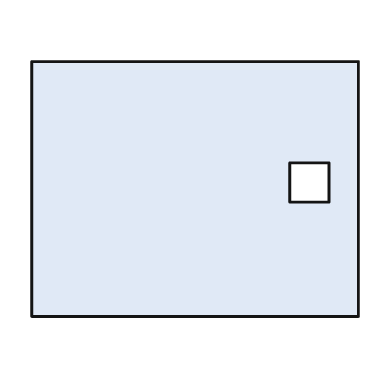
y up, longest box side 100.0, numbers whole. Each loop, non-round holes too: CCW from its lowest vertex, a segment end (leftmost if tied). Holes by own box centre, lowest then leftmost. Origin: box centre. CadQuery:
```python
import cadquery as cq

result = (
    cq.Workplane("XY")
    .moveTo(-50.0, -39.0)
    .lineTo(50.0, -39.0)
    .lineTo(50.0, 39.0)
    .lineTo(-50.0, 39.0)
    .close()
    .moveTo(29.0, -4.0)
    .lineTo(41.0, -4.0)
    .lineTo(41.0, 8.0)
    .lineTo(29.0, 8.0)
    .close()
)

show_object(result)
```